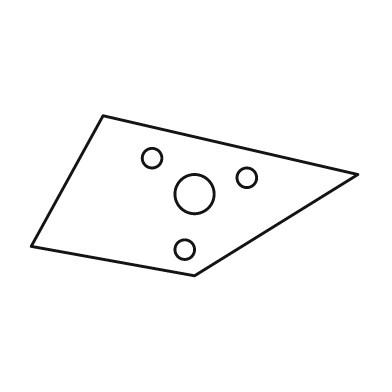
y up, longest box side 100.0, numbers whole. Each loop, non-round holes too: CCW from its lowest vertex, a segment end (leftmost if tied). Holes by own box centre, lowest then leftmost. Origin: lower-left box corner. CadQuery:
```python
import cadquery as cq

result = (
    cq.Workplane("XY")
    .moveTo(50.0, 0.0)
    .lineTo(100.0, 31.0)
    .lineTo(22.0, 49.0)
    .lineTo(0.0, 9.0)
    .close()
    .moveTo(47.0, 8.0)
    .circle(3.0)
    .moveTo(50.0, 25.0)
    .circle(6.0)
    .moveTo(66.0, 30.0)
    .circle(3.0)
    .moveTo(37.0, 36.0)
    .circle(3.0)
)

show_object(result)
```